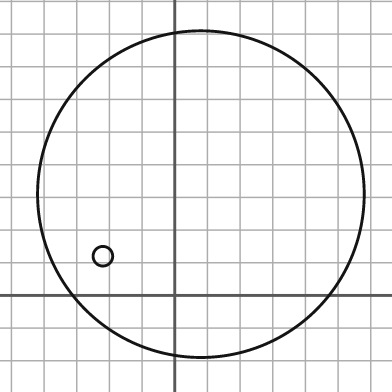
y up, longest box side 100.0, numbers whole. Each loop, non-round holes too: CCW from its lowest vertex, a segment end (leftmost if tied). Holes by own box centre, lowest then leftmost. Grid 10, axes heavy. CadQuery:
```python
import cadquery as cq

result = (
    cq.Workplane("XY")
    .moveTo(8.0, 31.0)
    .circle(50.0)
    .moveTo(-22.0, 12.0)
    .circle(3.0)
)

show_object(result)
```